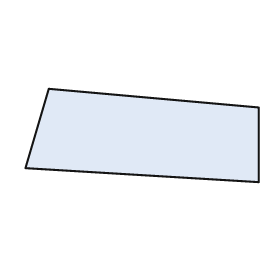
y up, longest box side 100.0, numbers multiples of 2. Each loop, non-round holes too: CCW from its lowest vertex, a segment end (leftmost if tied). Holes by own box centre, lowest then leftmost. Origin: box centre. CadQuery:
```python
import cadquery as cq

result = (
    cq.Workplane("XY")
    .moveTo(50.0, -20.0)
    .lineTo(50.0, 12.0)
    .lineTo(-40.0, 20.0)
    .lineTo(-50.0, -14.0)
    .close()
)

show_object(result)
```